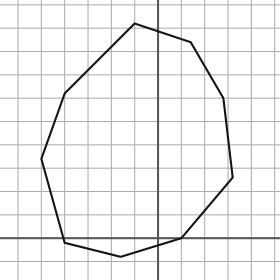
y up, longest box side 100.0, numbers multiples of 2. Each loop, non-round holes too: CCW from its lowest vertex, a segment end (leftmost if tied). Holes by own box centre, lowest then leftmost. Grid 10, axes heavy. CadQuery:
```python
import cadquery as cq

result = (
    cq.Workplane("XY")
    .moveTo(-16.0, -8.0)
    .lineTo(10.0, 0.0)
    .lineTo(32.0, 26.0)
    .lineTo(28.0, 60.0)
    .lineTo(14.0, 84.0)
    .lineTo(-10.0, 92.0)
    .lineTo(-40.0, 62.0)
    .lineTo(-50.0, 34.0)
    .lineTo(-40.0, -2.0)
    .close()
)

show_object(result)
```